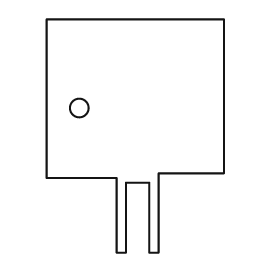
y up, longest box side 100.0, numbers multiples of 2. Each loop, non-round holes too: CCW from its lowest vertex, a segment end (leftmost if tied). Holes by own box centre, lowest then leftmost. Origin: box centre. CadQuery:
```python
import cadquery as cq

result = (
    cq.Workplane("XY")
    .moveTo(-8.0, -50.0)
    .lineTo(-4.0, -50.0)
    .lineTo(-4.0, -20.0)
    .lineTo(6.0, -20.0)
    .lineTo(6.0, -50.0)
    .lineTo(10.0, -50.0)
    .lineTo(10.0, -16.0)
    .lineTo(38.0, -16.0)
    .lineTo(38.0, 50.0)
    .lineTo(-38.0, 50.0)
    .lineTo(-38.0, -18.0)
    .lineTo(-8.0, -18.0)
    .close()
    .moveTo(-24.0, 12.0)
    .circle(4.0)
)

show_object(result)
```